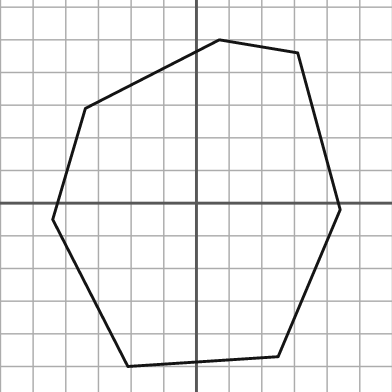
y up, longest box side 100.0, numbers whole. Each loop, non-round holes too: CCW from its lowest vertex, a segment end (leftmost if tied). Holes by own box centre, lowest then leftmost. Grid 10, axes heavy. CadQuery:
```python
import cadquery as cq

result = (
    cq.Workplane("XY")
    .moveTo(-21.0, -50.0)
    .lineTo(25.0, -47.0)
    .lineTo(44.0, -2.0)
    .lineTo(31.0, 46.0)
    .lineTo(7.0, 50.0)
    .lineTo(-34.0, 29.0)
    .lineTo(-44.0, -5.0)
    .close()
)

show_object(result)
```